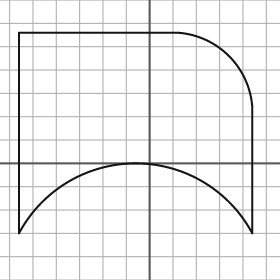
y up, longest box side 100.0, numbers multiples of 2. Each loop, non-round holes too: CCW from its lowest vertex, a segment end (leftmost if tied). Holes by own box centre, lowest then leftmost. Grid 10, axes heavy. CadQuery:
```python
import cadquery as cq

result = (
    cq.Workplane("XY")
    .moveTo(-56.0, -30.0)
    .threePointArc((-6.0, 0.0), (44.0, -30.0))
    .lineTo(44.0, 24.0)
    .threePointArc((34.0, 46.0), (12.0, 56.0))
    .lineTo(-56.0, 56.0)
    .close()
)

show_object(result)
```